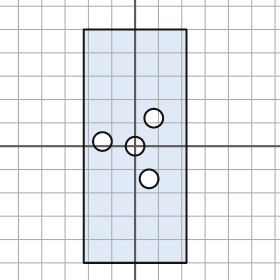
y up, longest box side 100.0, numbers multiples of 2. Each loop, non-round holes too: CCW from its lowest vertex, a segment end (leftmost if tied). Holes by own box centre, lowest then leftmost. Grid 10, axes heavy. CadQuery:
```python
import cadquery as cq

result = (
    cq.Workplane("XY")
    .moveTo(-22.0, -50.0)
    .lineTo(22.0, -50.0)
    .lineTo(22.0, 50.0)
    .lineTo(-22.0, 50.0)
    .close()
    .moveTo(6.0, -14.0)
    .circle(4.0)
    .moveTo(0.0, 0.0)
    .circle(4.0)
    .moveTo(-14.0, 2.0)
    .circle(4.0)
    .moveTo(8.0, 12.0)
    .circle(4.0)
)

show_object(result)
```